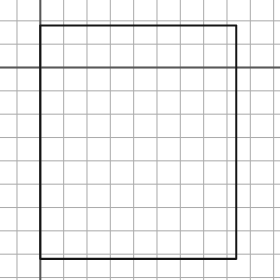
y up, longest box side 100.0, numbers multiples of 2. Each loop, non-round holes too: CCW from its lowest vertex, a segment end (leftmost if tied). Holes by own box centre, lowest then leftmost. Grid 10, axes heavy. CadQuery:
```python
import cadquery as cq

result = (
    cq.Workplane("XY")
    .moveTo(0.0, -82.0)
    .lineTo(84.0, -82.0)
    .lineTo(84.0, 18.0)
    .lineTo(0.0, 18.0)
    .close()
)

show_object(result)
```